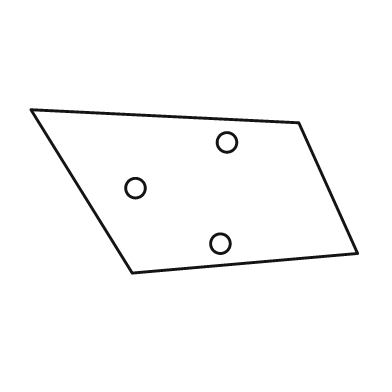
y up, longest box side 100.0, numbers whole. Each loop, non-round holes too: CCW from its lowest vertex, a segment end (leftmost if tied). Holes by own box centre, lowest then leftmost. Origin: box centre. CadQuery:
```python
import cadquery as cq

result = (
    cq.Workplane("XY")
    .moveTo(-19.0, -25.0)
    .lineTo(50.0, -19.0)
    .lineTo(32.0, 21.0)
    .lineTo(-50.0, 25.0)
    .close()
    .moveTo(8.0, -16.0)
    .circle(3.0)
    .moveTo(-18.0, 1.0)
    .circle(3.0)
    .moveTo(10.0, 15.0)
    .circle(3.0)
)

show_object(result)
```